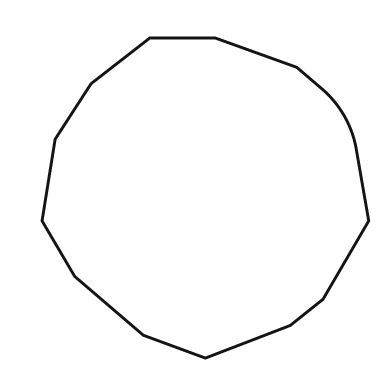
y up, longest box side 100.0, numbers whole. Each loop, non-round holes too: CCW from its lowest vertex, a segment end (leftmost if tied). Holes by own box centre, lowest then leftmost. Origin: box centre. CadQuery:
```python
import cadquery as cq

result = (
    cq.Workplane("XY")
    .moveTo(0.0, -49.0)
    .lineTo(26.0, -39.0)
    .lineTo(36.0, -31.0)
    .lineTo(50.0, -7.0)
    .lineTo(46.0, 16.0)
    .threePointArc((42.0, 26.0), (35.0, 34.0))
    .lineTo(28.0, 40.0)
    .lineTo(3.0, 49.0)
    .lineTo(-17.0, 49.0)
    .lineTo(-35.0, 35.0)
    .lineTo(-46.0, 18.0)
    .lineTo(-50.0, -7.0)
    .lineTo(-40.0, -24.0)
    .lineTo(-19.0, -42.0)
    .close()
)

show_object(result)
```